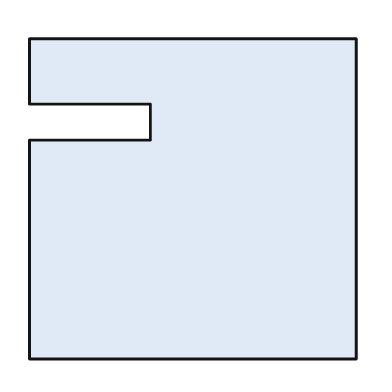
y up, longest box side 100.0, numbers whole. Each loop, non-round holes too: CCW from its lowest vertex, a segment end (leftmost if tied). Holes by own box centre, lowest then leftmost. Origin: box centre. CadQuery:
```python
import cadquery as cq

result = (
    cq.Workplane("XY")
    .moveTo(-50.0, -49.0)
    .lineTo(50.0, -49.0)
    .lineTo(50.0, 49.0)
    .lineTo(-50.0, 49.0)
    .lineTo(-50.0, 29.0)
    .lineTo(-13.0, 29.0)
    .lineTo(-13.0, 18.0)
    .lineTo(-50.0, 18.0)
    .close()
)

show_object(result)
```